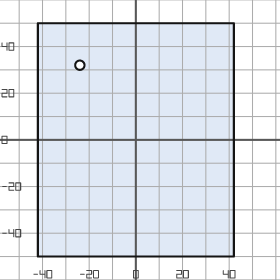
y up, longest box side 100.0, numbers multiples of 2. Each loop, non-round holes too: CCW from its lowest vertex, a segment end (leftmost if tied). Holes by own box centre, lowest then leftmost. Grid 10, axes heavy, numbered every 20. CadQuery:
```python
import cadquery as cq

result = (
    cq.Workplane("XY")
    .moveTo(-42.0, -50.0)
    .lineTo(42.0, -50.0)
    .lineTo(42.0, 50.0)
    .lineTo(-42.0, 50.0)
    .close()
    .moveTo(-24.0, 32.0)
    .circle(2.0)
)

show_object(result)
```